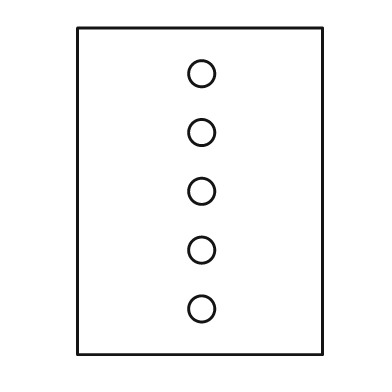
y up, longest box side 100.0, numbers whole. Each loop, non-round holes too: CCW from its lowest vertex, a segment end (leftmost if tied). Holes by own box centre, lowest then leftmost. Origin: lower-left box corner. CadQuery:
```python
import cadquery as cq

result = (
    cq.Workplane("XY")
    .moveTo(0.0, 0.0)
    .lineTo(75.0, 0.0)
    .lineTo(75.0, 100.0)
    .lineTo(0.0, 100.0)
    .close()
    .moveTo(38.0, 14.0)
    .circle(4.0)
    .moveTo(38.0, 32.0)
    .circle(4.0)
    .moveTo(38.0, 50.0)
    .circle(4.0)
    .moveTo(38.0, 68.0)
    .circle(4.0)
    .moveTo(38.0, 86.0)
    .circle(4.0)
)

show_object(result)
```